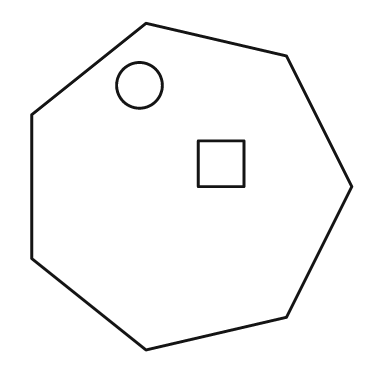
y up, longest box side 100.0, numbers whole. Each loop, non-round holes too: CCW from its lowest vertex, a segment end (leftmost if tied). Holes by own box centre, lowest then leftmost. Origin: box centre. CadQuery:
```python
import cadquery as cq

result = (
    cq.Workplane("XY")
    .moveTo(-14.0, -50.0)
    .lineTo(29.0, -40.0)
    .lineTo(49.0, 0.0)
    .lineTo(29.0, 40.0)
    .lineTo(-14.0, 50.0)
    .lineTo(-49.0, 22.0)
    .lineTo(-49.0, -22.0)
    .close()
    .moveTo(2.0, 0.0)
    .lineTo(16.0, 0.0)
    .lineTo(16.0, 14.0)
    .lineTo(2.0, 14.0)
    .close()
    .moveTo(-16.0, 31.0)
    .circle(7.0)
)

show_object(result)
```